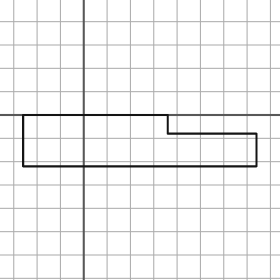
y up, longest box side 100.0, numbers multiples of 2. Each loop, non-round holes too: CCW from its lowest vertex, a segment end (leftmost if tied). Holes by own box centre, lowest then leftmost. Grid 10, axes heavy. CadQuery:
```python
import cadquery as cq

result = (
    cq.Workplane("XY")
    .moveTo(-26.0, -22.0)
    .lineTo(74.0, -22.0)
    .lineTo(74.0, -8.0)
    .lineTo(36.0, -8.0)
    .lineTo(36.0, 0.0)
    .lineTo(-26.0, 0.0)
    .close()
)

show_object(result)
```